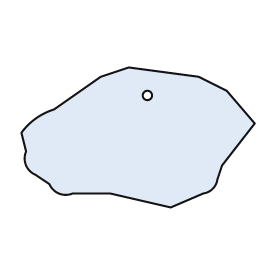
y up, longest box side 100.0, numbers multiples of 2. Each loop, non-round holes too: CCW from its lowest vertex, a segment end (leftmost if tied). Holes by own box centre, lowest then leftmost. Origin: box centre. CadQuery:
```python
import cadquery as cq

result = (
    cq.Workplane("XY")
    .moveTo(14.0, -30.0)
    .lineTo(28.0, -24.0)
    .threePointArc((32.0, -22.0), (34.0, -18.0))
    .lineTo(36.0, -12.0)
    .lineTo(50.0, 6.0)
    .lineTo(38.0, 20.0)
    .lineTo(26.0, 26.0)
    .lineTo(-4.0, 30.0)
    .lineTo(-16.0, 26.0)
    .lineTo(-36.0, 12.0)
    .threePointArc((-44.0, 8.0), (-50.0, 2.0))
    .lineTo(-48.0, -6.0)
    .threePointArc((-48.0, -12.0), (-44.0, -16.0))
    .lineTo(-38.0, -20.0)
    .threePointArc((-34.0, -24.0), (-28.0, -24.0))
    .lineTo(-12.0, -24.0)
    .close()
    .moveTo(4.0, 18.0)
    .circle(2.0)
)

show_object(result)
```